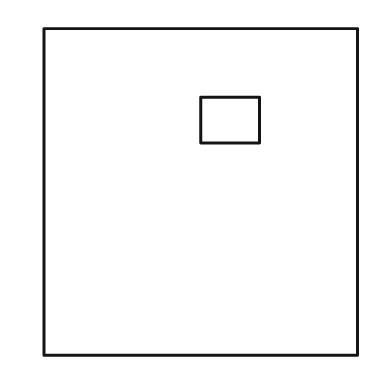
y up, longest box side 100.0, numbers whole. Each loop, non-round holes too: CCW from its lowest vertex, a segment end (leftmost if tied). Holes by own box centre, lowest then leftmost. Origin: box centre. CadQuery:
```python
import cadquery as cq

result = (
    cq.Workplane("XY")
    .moveTo(-48.0, -50.0)
    .lineTo(48.0, -50.0)
    .lineTo(48.0, 50.0)
    .lineTo(-48.0, 50.0)
    .close()
    .moveTo(0.0, 15.0)
    .lineTo(18.0, 15.0)
    .lineTo(18.0, 29.0)
    .lineTo(0.0, 29.0)
    .close()
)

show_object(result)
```